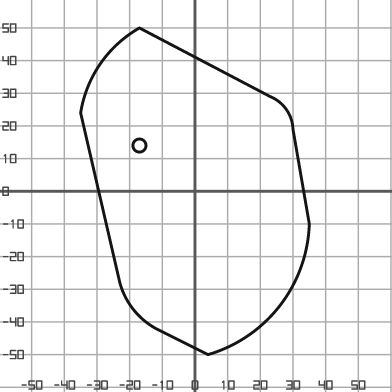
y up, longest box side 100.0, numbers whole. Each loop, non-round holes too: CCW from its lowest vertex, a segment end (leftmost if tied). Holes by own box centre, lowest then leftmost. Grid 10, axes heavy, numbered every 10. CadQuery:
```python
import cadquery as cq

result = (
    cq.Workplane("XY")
    .moveTo(4.0, -50.0)
    .threePointArc((26.0, -35.0), (35.0, -10.0))
    .lineTo(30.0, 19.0)
    .threePointArc((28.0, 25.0), (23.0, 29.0))
    .lineTo(-17.0, 50.0)
    .threePointArc((-29.0, 39.0), (-35.0, 24.0))
    .lineTo(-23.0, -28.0)
    .threePointArc((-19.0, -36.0), (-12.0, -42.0))
    .close()
    .moveTo(-17.0, 14.0)
    .circle(2.0)
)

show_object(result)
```